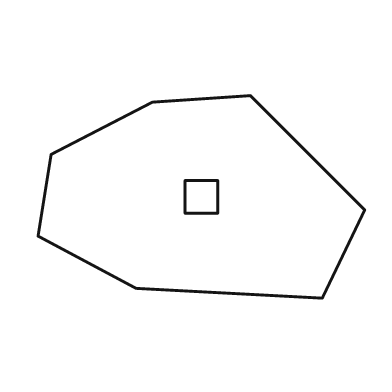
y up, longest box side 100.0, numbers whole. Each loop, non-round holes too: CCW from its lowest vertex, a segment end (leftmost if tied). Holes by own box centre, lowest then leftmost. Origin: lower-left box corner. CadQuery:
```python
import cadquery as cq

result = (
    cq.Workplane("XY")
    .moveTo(87.0, 0.0)
    .lineTo(100.0, 27.0)
    .lineTo(65.0, 62.0)
    .lineTo(35.0, 60.0)
    .lineTo(4.0, 44.0)
    .lineTo(0.0, 19.0)
    .lineTo(30.0, 3.0)
    .close()
    .moveTo(45.0, 26.0)
    .lineTo(55.0, 26.0)
    .lineTo(55.0, 36.0)
    .lineTo(45.0, 36.0)
    .close()
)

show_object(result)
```